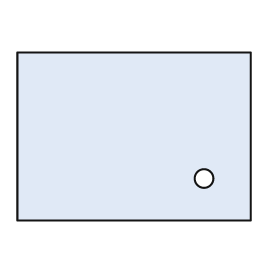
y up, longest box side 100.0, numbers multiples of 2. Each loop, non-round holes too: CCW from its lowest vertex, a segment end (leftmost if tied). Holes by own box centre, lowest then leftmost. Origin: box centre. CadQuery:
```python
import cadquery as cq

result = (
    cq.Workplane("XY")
    .moveTo(-50.0, -36.0)
    .lineTo(50.0, -36.0)
    .lineTo(50.0, 36.0)
    .lineTo(-50.0, 36.0)
    .close()
    .moveTo(30.0, -18.0)
    .circle(4.0)
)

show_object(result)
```